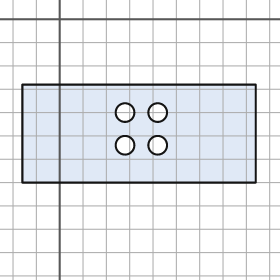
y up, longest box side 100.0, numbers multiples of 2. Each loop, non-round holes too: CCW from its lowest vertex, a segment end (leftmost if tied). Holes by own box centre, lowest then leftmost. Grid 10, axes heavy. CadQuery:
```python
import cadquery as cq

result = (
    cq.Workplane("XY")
    .moveTo(-16.0, -70.0)
    .lineTo(84.0, -70.0)
    .lineTo(84.0, -28.0)
    .lineTo(-16.0, -28.0)
    .close()
    .moveTo(28.0, -54.0)
    .circle(4.0)
    .moveTo(42.0, -54.0)
    .circle(4.0)
    .moveTo(28.0, -40.0)
    .circle(4.0)
    .moveTo(42.0, -40.0)
    .circle(4.0)
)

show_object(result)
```